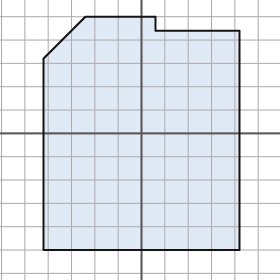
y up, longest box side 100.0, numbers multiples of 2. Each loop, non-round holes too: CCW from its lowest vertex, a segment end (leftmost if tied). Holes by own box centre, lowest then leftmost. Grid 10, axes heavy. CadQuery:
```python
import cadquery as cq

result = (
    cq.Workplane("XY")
    .moveTo(-42.0, -50.0)
    .lineTo(42.0, -50.0)
    .lineTo(42.0, 44.0)
    .lineTo(6.0, 44.0)
    .lineTo(6.0, 50.0)
    .lineTo(-24.0, 50.0)
    .lineTo(-42.0, 32.0)
    .close()
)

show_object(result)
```